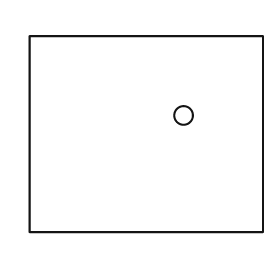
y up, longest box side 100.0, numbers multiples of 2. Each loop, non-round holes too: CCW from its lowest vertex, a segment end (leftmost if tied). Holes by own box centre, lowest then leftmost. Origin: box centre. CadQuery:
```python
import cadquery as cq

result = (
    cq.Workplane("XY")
    .moveTo(-50.0, -42.0)
    .lineTo(50.0, -42.0)
    .lineTo(50.0, 42.0)
    .lineTo(-50.0, 42.0)
    .close()
    .moveTo(16.0, 8.0)
    .circle(4.0)
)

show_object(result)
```